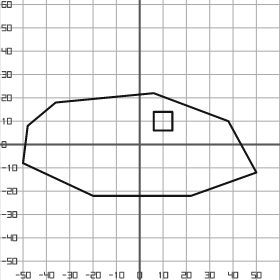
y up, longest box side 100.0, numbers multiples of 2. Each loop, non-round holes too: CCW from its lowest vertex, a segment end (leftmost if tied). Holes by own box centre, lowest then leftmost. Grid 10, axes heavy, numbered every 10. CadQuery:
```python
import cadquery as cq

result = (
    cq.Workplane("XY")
    .moveTo(-20.0, -22.0)
    .lineTo(22.0, -22.0)
    .lineTo(50.0, -12.0)
    .lineTo(38.0, 10.0)
    .lineTo(6.0, 22.0)
    .lineTo(-36.0, 18.0)
    .lineTo(-48.0, 8.0)
    .lineTo(-50.0, -8.0)
    .close()
    .moveTo(6.0, 6.0)
    .lineTo(14.0, 6.0)
    .lineTo(14.0, 14.0)
    .lineTo(6.0, 14.0)
    .close()
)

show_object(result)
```